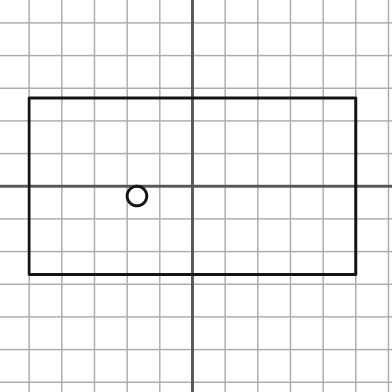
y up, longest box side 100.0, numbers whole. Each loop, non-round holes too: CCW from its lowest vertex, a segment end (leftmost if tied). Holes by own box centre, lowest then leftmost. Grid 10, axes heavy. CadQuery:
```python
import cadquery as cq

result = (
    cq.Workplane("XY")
    .moveTo(-50.0, -27.0)
    .lineTo(50.0, -27.0)
    .lineTo(50.0, 27.0)
    .lineTo(-50.0, 27.0)
    .close()
    .moveTo(-17.0, -3.0)
    .circle(3.0)
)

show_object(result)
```